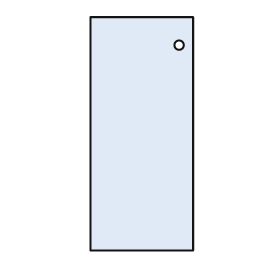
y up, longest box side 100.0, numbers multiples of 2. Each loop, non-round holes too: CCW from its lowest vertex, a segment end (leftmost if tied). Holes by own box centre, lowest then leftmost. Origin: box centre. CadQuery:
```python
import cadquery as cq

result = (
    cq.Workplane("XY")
    .moveTo(-22.0, -50.0)
    .lineTo(22.0, -50.0)
    .lineTo(22.0, 50.0)
    .lineTo(-22.0, 50.0)
    .close()
    .moveTo(16.0, 38.0)
    .circle(2.0)
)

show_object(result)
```